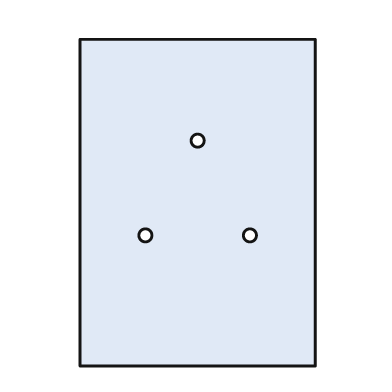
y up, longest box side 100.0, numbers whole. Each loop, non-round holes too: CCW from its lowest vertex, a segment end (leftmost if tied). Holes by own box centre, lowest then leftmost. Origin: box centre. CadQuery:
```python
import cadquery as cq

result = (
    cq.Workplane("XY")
    .moveTo(-36.0, -50.0)
    .lineTo(36.0, -50.0)
    .lineTo(36.0, 50.0)
    .lineTo(-36.0, 50.0)
    .close()
    .moveTo(-16.0, -10.0)
    .circle(2.0)
    .moveTo(16.0, -10.0)
    .circle(2.0)
    .moveTo(0.0, 19.0)
    .circle(2.0)
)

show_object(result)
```